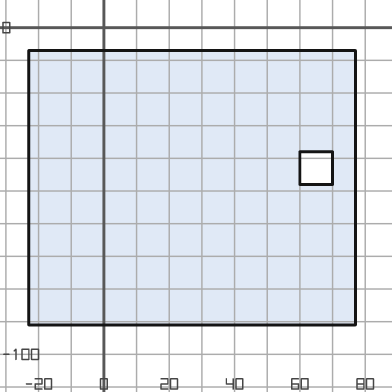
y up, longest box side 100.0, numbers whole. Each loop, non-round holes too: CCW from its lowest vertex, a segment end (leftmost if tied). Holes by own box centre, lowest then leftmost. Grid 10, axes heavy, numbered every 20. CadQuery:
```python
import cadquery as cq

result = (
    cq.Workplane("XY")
    .moveTo(-23.0, -91.0)
    .lineTo(77.0, -91.0)
    .lineTo(77.0, -7.0)
    .lineTo(-23.0, -7.0)
    .close()
    .moveTo(60.0, -48.0)
    .lineTo(70.0, -48.0)
    .lineTo(70.0, -38.0)
    .lineTo(60.0, -38.0)
    .close()
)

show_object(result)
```